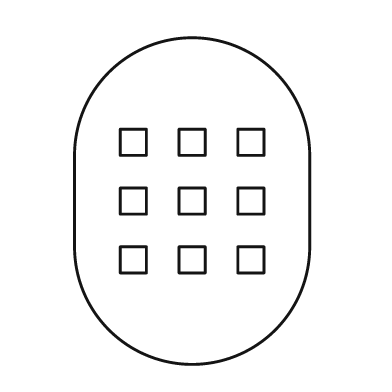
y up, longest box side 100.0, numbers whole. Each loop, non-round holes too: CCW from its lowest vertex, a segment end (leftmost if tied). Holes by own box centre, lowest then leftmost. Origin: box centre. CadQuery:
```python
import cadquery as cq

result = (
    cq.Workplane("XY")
    .moveTo(-36.0, -14.0)
    .threePointArc((0.0, -50.0), (36.0, -14.0))
    .lineTo(36.0, 14.0)
    .threePointArc((0.0, 50.0), (-36.0, 14.0))
    .close()
    .moveTo(-22.0, -22.0)
    .lineTo(-14.0, -22.0)
    .lineTo(-14.0, -14.0)
    .lineTo(-22.0, -14.0)
    .close()
    .moveTo(-4.0, -22.0)
    .lineTo(4.0, -22.0)
    .lineTo(4.0, -14.0)
    .lineTo(-4.0, -14.0)
    .close()
    .moveTo(14.0, -22.0)
    .lineTo(22.0, -22.0)
    .lineTo(22.0, -14.0)
    .lineTo(14.0, -14.0)
    .close()
    .moveTo(-22.0, -4.0)
    .lineTo(-14.0, -4.0)
    .lineTo(-14.0, 4.0)
    .lineTo(-22.0, 4.0)
    .close()
    .moveTo(-4.0, -4.0)
    .lineTo(4.0, -4.0)
    .lineTo(4.0, 4.0)
    .lineTo(-4.0, 4.0)
    .close()
    .moveTo(14.0, -4.0)
    .lineTo(22.0, -4.0)
    .lineTo(22.0, 4.0)
    .lineTo(14.0, 4.0)
    .close()
    .moveTo(-22.0, 14.0)
    .lineTo(-14.0, 14.0)
    .lineTo(-14.0, 22.0)
    .lineTo(-22.0, 22.0)
    .close()
    .moveTo(-4.0, 14.0)
    .lineTo(4.0, 14.0)
    .lineTo(4.0, 22.0)
    .lineTo(-4.0, 22.0)
    .close()
    .moveTo(14.0, 14.0)
    .lineTo(22.0, 14.0)
    .lineTo(22.0, 22.0)
    .lineTo(14.0, 22.0)
    .close()
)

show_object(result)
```